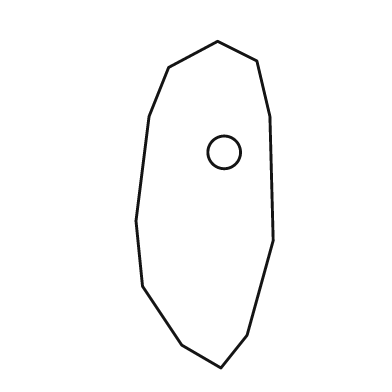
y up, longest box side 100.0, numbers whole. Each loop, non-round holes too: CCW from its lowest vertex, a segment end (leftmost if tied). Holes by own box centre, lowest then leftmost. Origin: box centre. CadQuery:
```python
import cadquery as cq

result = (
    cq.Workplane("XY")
    .moveTo(5.0, -50.0)
    .lineTo(13.0, -40.0)
    .lineTo(21.0, -11.0)
    .lineTo(20.0, 27.0)
    .lineTo(16.0, 44.0)
    .lineTo(4.0, 50.0)
    .lineTo(-11.0, 42.0)
    .lineTo(-17.0, 27.0)
    .lineTo(-21.0, -5.0)
    .lineTo(-19.0, -25.0)
    .lineTo(-7.0, -43.0)
    .close()
    .moveTo(6.0, 16.0)
    .circle(5.0)
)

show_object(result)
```